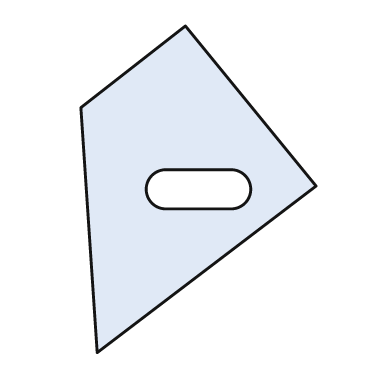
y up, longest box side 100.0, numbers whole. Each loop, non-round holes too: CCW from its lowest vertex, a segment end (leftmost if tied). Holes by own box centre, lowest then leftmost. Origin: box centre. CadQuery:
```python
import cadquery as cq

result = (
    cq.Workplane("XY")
    .moveTo(-31.0, -50.0)
    .lineTo(36.0, 1.0)
    .lineTo(-4.0, 50.0)
    .lineTo(-36.0, 25.0)
    .close()
    .moveTo(-10.0, -6.0)
    .lineTo(10.0, -6.0)
    .threePointArc((16.0, 0.0), (10.0, 6.0))
    .lineTo(-10.0, 6.0)
    .threePointArc((-16.0, 0.0), (-10.0, -6.0))
    .close()
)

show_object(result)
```